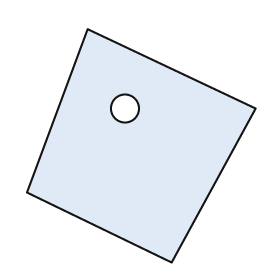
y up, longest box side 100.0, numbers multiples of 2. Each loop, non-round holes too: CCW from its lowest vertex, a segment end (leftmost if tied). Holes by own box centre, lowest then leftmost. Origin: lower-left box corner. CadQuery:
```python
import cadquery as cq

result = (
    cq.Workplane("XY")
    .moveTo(62.0, 0.0)
    .lineTo(98.0, 66.0)
    .lineTo(26.0, 100.0)
    .lineTo(0.0, 30.0)
    .close()
    .moveTo(42.0, 66.0)
    .circle(6.0)
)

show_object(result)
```